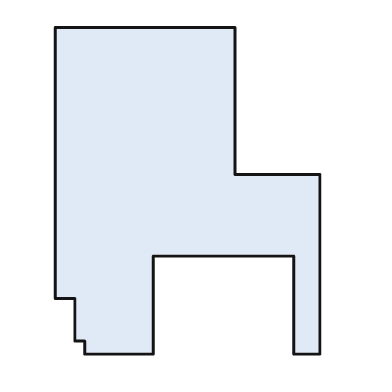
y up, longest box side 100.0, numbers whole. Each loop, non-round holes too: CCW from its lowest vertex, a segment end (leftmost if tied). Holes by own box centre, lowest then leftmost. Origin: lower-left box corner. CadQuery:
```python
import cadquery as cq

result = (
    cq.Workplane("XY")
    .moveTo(9.0, 0.0)
    .lineTo(30.0, 0.0)
    .lineTo(30.0, 30.0)
    .lineTo(73.0, 30.0)
    .lineTo(73.0, 0.0)
    .lineTo(81.0, 0.0)
    .lineTo(81.0, 55.0)
    .lineTo(55.0, 55.0)
    .lineTo(55.0, 100.0)
    .lineTo(0.0, 100.0)
    .lineTo(0.0, 17.0)
    .lineTo(6.0, 17.0)
    .lineTo(6.0, 4.0)
    .lineTo(9.0, 4.0)
    .close()
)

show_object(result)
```